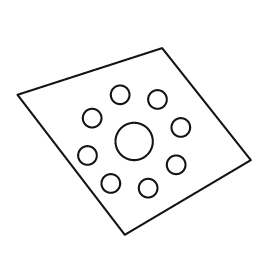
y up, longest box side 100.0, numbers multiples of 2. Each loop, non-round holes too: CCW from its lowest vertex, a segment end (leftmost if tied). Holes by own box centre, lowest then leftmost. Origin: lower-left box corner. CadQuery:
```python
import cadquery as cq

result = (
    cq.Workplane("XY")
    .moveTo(46.0, 0.0)
    .lineTo(100.0, 32.0)
    .lineTo(62.0, 80.0)
    .lineTo(0.0, 60.0)
    .close()
    .moveTo(56.0, 20.0)
    .circle(4.0)
    .moveTo(40.0, 22.0)
    .circle(4.0)
    .moveTo(68.0, 30.0)
    .circle(4.0)
    .moveTo(30.0, 34.0)
    .circle(4.0)
    .moveTo(50.0, 40.0)
    .circle(8.0)
    .moveTo(70.0, 46.0)
    .circle(4.0)
    .moveTo(32.0, 50.0)
    .circle(4.0)
    .moveTo(60.0, 58.0)
    .circle(4.0)
    .moveTo(44.0, 60.0)
    .circle(4.0)
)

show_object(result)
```